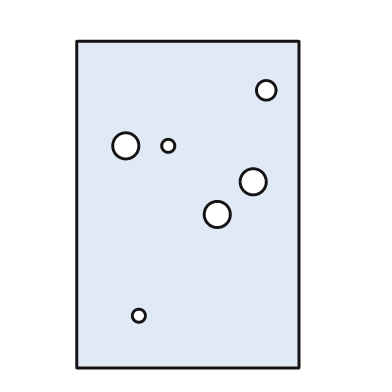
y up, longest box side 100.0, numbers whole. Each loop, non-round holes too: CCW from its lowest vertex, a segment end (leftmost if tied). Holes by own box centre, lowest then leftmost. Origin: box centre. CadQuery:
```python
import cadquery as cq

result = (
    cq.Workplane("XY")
    .moveTo(-34.0, -50.0)
    .lineTo(34.0, -50.0)
    .lineTo(34.0, 50.0)
    .lineTo(-34.0, 50.0)
    .close()
    .moveTo(-15.0, -34.0)
    .circle(2.0)
    .moveTo(9.0, -3.0)
    .circle(4.0)
    .moveTo(20.0, 7.0)
    .circle(4.0)
    .moveTo(-19.0, 18.0)
    .circle(4.0)
    .moveTo(-6.0, 18.0)
    .circle(2.0)
    .moveTo(24.0, 35.0)
    .circle(3.0)
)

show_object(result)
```